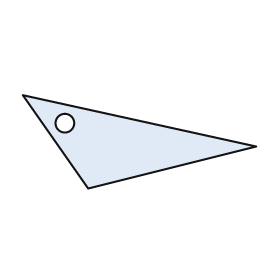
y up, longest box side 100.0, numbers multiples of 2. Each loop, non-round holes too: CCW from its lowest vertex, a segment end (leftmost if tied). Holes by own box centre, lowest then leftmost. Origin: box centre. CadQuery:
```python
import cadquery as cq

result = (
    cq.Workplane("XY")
    .moveTo(-22.0, -20.0)
    .lineTo(50.0, -2.0)
    .lineTo(-50.0, 20.0)
    .close()
    .moveTo(-32.0, 8.0)
    .circle(4.0)
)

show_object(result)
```